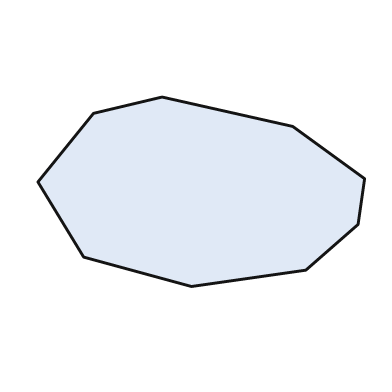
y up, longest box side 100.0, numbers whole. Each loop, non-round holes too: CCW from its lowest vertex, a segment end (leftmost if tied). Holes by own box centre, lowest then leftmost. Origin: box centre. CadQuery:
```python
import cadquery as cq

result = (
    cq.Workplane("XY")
    .moveTo(-3.0, -29.0)
    .lineTo(32.0, -24.0)
    .lineTo(48.0, -10.0)
    .lineTo(50.0, 4.0)
    .lineTo(28.0, 20.0)
    .lineTo(-12.0, 29.0)
    .lineTo(-33.0, 24.0)
    .lineTo(-50.0, 3.0)
    .lineTo(-36.0, -20.0)
    .close()
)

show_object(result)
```